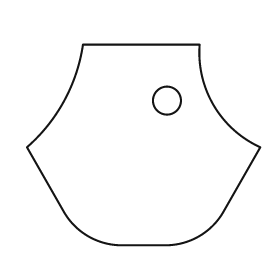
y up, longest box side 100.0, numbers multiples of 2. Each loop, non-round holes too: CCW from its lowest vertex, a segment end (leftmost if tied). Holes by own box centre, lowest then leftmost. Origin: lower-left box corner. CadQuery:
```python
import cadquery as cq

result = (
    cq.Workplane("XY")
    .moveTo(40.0, 0.0)
    .lineTo(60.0, 0.0)
    .threePointArc((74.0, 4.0), (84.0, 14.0))
    .lineTo(100.0, 42.0)
    .threePointArc((80.0, 60.0), (74.0, 86.0))
    .lineTo(24.0, 86.0)
    .threePointArc((16.0, 62.0), (0.0, 42.0))
    .lineTo(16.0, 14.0)
    .threePointArc((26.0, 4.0), (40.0, 0.0))
    .close()
    .moveTo(60.0, 62.0)
    .circle(6.0)
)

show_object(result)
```